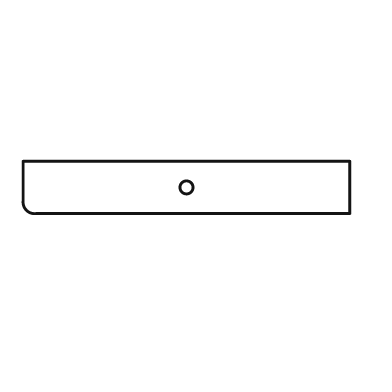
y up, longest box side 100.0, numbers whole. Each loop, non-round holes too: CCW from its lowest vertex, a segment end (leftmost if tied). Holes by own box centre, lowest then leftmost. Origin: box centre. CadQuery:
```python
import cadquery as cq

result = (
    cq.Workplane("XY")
    .moveTo(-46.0, -8.0)
    .lineTo(50.0, -8.0)
    .lineTo(50.0, 8.0)
    .lineTo(-50.0, 8.0)
    .lineTo(-50.0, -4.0)
    .threePointArc((-49.0, -7.0), (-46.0, -8.0))
    .close()
    .moveTo(0.0, 0.0)
    .circle(2.0)
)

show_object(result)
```